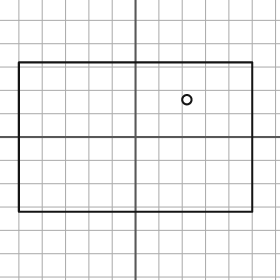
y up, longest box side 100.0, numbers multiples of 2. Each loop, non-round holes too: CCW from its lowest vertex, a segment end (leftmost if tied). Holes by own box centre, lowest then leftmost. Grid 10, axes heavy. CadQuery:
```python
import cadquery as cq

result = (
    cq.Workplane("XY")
    .moveTo(-50.0, -32.0)
    .lineTo(50.0, -32.0)
    .lineTo(50.0, 32.0)
    .lineTo(-50.0, 32.0)
    .close()
    .moveTo(22.0, 16.0)
    .circle(2.0)
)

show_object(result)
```